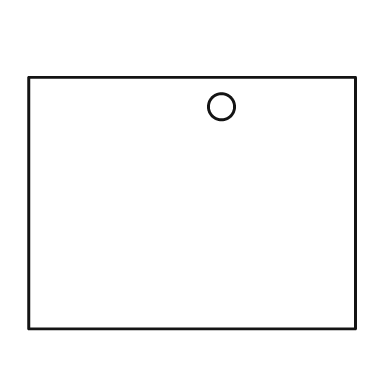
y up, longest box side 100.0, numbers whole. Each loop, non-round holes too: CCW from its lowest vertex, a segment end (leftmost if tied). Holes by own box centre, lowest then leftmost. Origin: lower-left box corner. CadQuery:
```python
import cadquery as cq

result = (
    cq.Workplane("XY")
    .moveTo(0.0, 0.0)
    .lineTo(100.0, 0.0)
    .lineTo(100.0, 77.0)
    .lineTo(0.0, 77.0)
    .close()
    .moveTo(59.0, 68.0)
    .circle(4.0)
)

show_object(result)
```